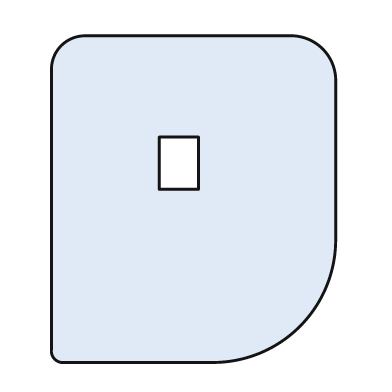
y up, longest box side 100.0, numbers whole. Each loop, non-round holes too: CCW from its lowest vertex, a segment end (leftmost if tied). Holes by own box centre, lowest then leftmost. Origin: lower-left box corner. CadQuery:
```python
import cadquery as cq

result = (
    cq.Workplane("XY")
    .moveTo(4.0, 0.0)
    .lineTo(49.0, 0.0)
    .threePointArc((76.0, 11.0), (87.0, 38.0))
    .lineTo(87.0, 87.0)
    .threePointArc((83.0, 96.0), (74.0, 100.0))
    .lineTo(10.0, 100.0)
    .threePointArc((3.0, 97.0), (0.0, 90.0))
    .lineTo(0.0, 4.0)
    .threePointArc((1.0, 1.0), (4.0, 0.0))
    .close()
    .moveTo(33.0, 53.0)
    .lineTo(45.0, 53.0)
    .lineTo(45.0, 69.0)
    .lineTo(33.0, 69.0)
    .close()
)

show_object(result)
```